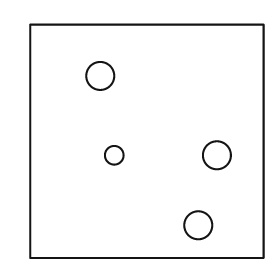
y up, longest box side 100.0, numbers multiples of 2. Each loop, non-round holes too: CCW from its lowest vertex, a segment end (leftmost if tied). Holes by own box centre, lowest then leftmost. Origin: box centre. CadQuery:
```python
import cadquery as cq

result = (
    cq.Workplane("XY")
    .moveTo(-50.0, -50.0)
    .lineTo(50.0, -50.0)
    .lineTo(50.0, 50.0)
    .lineTo(-50.0, 50.0)
    .close()
    .moveTo(22.0, -36.0)
    .circle(6.0)
    .moveTo(-14.0, -6.0)
    .circle(4.0)
    .moveTo(30.0, -6.0)
    .circle(6.0)
    .moveTo(-20.0, 28.0)
    .circle(6.0)
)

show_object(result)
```